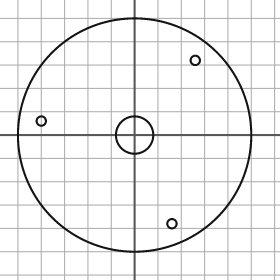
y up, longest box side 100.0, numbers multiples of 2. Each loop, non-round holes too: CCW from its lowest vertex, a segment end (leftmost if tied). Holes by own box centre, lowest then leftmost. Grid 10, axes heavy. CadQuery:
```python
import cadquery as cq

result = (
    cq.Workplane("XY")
    .moveTo(0.0, 0.0)
    .circle(50.0)
    .moveTo(16.0, -38.0)
    .circle(2.0)
    .moveTo(0.0, 0.0)
    .circle(8.0)
    .moveTo(-40.0, 6.0)
    .circle(2.0)
    .moveTo(26.0, 32.0)
    .circle(2.0)
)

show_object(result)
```